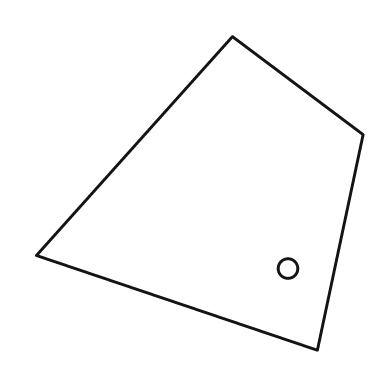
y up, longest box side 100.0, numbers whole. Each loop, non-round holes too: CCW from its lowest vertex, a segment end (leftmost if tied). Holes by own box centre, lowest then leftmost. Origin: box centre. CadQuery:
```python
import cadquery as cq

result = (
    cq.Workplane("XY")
    .moveTo(36.0, -48.0)
    .lineTo(50.0, 18.0)
    .lineTo(10.0, 48.0)
    .lineTo(-50.0, -19.0)
    .close()
    .moveTo(27.0, -23.0)
    .circle(3.0)
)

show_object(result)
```